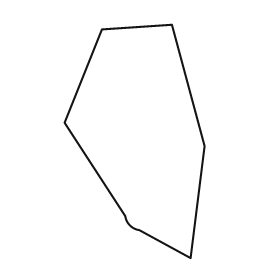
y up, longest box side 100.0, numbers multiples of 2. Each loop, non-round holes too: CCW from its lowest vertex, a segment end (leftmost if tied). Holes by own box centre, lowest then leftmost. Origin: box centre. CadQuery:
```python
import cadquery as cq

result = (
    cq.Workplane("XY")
    .moveTo(24.0, -50.0)
    .lineTo(30.0, -2.0)
    .lineTo(16.0, 50.0)
    .lineTo(-14.0, 48.0)
    .lineTo(-30.0, 8.0)
    .lineTo(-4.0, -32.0)
    .threePointArc((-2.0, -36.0), (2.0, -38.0))
    .close()
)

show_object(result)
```